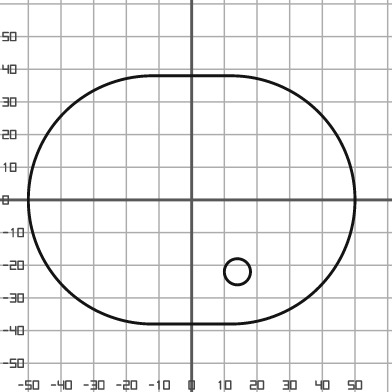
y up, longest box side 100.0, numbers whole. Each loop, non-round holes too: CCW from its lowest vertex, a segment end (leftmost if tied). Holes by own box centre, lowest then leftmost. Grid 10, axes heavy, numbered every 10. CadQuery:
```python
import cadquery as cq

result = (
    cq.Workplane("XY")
    .moveTo(-12.0, -38.0)
    .lineTo(12.0, -38.0)
    .threePointArc((50.0, 0.0), (12.0, 38.0))
    .lineTo(-12.0, 38.0)
    .threePointArc((-50.0, 0.0), (-12.0, -38.0))
    .close()
    .moveTo(14.0, -22.0)
    .circle(4.0)
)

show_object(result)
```